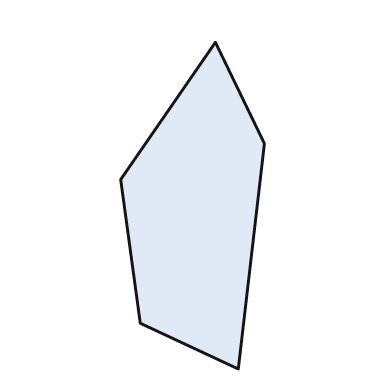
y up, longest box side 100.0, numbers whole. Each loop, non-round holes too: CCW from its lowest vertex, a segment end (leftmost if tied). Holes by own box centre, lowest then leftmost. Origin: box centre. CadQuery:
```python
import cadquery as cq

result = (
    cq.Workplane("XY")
    .moveTo(14.0, -50.0)
    .lineTo(22.0, 19.0)
    .lineTo(7.0, 50.0)
    .lineTo(-22.0, 8.0)
    .lineTo(-16.0, -36.0)
    .close()
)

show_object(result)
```